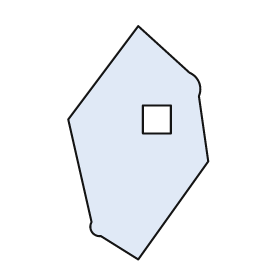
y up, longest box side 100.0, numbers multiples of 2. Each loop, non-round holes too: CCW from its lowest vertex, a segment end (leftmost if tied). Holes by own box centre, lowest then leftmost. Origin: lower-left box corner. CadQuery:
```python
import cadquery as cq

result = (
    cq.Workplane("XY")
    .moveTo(30.0, 0.0)
    .lineTo(60.0, 42.0)
    .lineTo(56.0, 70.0)
    .threePointArc((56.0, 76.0), (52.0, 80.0))
    .lineTo(30.0, 100.0)
    .lineTo(0.0, 60.0)
    .lineTo(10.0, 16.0)
    .threePointArc((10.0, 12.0), (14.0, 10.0))
    .close()
    .moveTo(32.0, 54.0)
    .lineTo(44.0, 54.0)
    .lineTo(44.0, 66.0)
    .lineTo(32.0, 66.0)
    .close()
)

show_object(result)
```